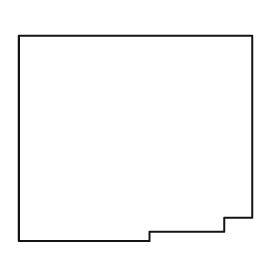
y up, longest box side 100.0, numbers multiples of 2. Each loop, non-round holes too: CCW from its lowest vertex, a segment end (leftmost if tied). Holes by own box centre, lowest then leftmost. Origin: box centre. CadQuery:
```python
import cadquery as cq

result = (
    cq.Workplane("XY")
    .moveTo(-50.0, -44.0)
    .lineTo(6.0, -44.0)
    .lineTo(6.0, -40.0)
    .lineTo(38.0, -40.0)
    .lineTo(38.0, -34.0)
    .lineTo(50.0, -34.0)
    .lineTo(50.0, 44.0)
    .lineTo(-50.0, 44.0)
    .close()
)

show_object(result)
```